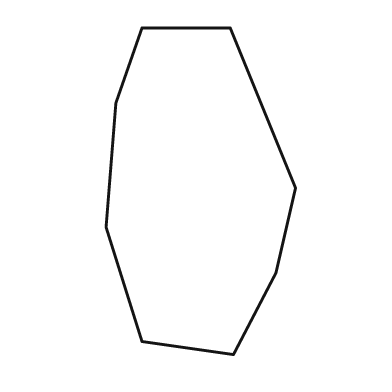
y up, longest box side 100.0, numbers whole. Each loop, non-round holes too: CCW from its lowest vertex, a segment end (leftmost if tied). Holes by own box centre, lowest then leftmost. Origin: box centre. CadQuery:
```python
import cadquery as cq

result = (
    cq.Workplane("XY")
    .moveTo(10.0, -50.0)
    .lineTo(23.0, -25.0)
    .lineTo(29.0, 1.0)
    .lineTo(9.0, 50.0)
    .lineTo(-18.0, 50.0)
    .lineTo(-26.0, 27.0)
    .lineTo(-29.0, -11.0)
    .lineTo(-18.0, -46.0)
    .close()
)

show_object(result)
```